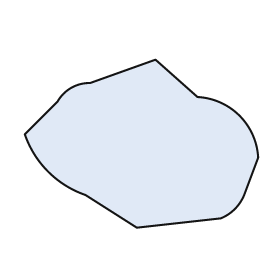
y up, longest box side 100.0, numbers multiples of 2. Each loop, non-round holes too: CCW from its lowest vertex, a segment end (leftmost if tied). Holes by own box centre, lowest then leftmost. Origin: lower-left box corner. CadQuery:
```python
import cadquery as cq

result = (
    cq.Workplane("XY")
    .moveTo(48.0, 0.0)
    .lineTo(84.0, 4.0)
    .threePointArc((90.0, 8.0), (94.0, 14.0))
    .lineTo(100.0, 30.0)
    .threePointArc((92.0, 48.0), (74.0, 56.0))
    .lineTo(56.0, 72.0)
    .lineTo(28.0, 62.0)
    .threePointArc((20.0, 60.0), (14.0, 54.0))
    .lineTo(0.0, 40.0)
    .threePointArc((10.0, 24.0), (26.0, 14.0))
    .close()
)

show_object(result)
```